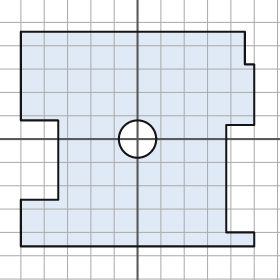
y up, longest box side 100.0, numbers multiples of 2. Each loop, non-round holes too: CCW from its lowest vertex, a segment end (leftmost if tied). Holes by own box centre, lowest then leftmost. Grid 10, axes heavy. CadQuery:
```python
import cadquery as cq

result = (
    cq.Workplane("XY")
    .moveTo(-50.0, -46.0)
    .lineTo(50.0, -46.0)
    .lineTo(50.0, -40.0)
    .lineTo(38.0, -40.0)
    .lineTo(38.0, 6.0)
    .lineTo(50.0, 6.0)
    .lineTo(50.0, 32.0)
    .lineTo(46.0, 32.0)
    .lineTo(46.0, 46.0)
    .lineTo(-50.0, 46.0)
    .lineTo(-50.0, 8.0)
    .lineTo(-34.0, 8.0)
    .lineTo(-34.0, -26.0)
    .lineTo(-50.0, -26.0)
    .close()
    .moveTo(0.0, 0.0)
    .circle(8.0)
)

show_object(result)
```